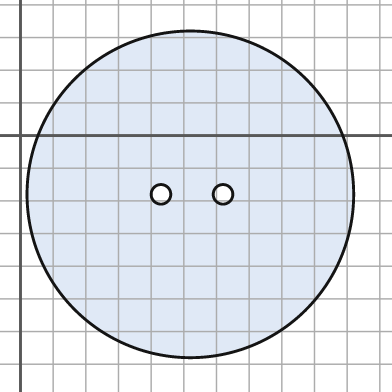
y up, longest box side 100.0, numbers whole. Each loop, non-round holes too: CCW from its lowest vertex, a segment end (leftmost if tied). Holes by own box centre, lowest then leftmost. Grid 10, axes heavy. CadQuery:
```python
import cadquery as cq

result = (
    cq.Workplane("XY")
    .moveTo(52.0, -18.0)
    .circle(50.0)
    .moveTo(43.0, -18.0)
    .circle(3.0)
    .moveTo(62.0, -18.0)
    .circle(3.0)
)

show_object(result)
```